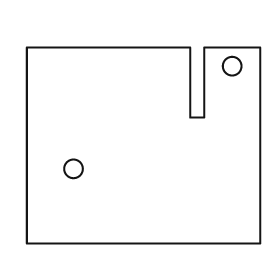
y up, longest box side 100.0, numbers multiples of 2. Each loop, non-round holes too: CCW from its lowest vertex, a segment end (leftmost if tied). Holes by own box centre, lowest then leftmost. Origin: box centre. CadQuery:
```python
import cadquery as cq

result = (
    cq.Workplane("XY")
    .moveTo(-50.0, -42.0)
    .lineTo(50.0, -42.0)
    .lineTo(50.0, 42.0)
    .lineTo(26.0, 42.0)
    .lineTo(26.0, 12.0)
    .lineTo(20.0, 12.0)
    .lineTo(20.0, 42.0)
    .lineTo(-50.0, 42.0)
    .close()
    .moveTo(-30.0, -10.0)
    .circle(4.0)
    .moveTo(38.0, 34.0)
    .circle(4.0)
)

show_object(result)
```